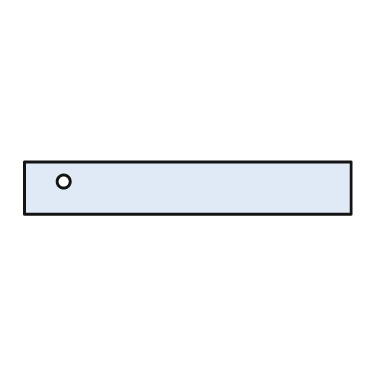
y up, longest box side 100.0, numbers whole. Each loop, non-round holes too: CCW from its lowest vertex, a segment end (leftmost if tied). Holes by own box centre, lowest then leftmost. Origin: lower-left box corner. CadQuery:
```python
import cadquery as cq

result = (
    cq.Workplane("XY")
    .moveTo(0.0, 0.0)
    .lineTo(100.0, 0.0)
    .lineTo(100.0, 16.0)
    .lineTo(0.0, 16.0)
    .close()
    .moveTo(12.0, 10.0)
    .circle(2.0)
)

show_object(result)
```